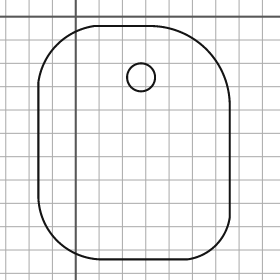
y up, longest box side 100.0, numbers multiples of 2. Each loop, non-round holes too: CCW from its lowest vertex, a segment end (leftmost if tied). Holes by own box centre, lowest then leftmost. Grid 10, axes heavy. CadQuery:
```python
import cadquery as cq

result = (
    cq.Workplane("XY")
    .moveTo(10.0, -104.0)
    .lineTo(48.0, -104.0)
    .threePointArc((60.0, -98.0), (66.0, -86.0))
    .lineTo(66.0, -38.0)
    .threePointArc((56.0, -14.0), (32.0, -4.0))
    .lineTo(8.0, -4.0)
    .threePointArc((-8.0, -12.0), (-16.0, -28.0))
    .lineTo(-16.0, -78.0)
    .threePointArc((-8.0, -96.0), (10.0, -104.0))
    .close()
    .moveTo(28.0, -26.0)
    .circle(6.0)
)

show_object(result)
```